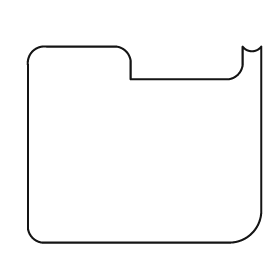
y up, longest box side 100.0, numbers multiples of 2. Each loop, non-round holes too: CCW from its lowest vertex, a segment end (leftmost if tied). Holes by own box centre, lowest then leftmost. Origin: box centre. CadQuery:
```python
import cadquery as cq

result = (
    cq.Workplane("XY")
    .moveTo(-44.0, -42.0)
    .lineTo(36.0, -42.0)
    .threePointArc((46.0, -38.0), (50.0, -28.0))
    .lineTo(50.0, 42.0)
    .threePointArc((46.0, 40.0), (42.0, 42.0))
    .lineTo(42.0, 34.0)
    .threePointArc((40.0, 30.0), (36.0, 28.0))
    .lineTo(-6.0, 28.0)
    .lineTo(-6.0, 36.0)
    .threePointArc((-8.0, 40.0), (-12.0, 42.0))
    .lineTo(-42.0, 42.0)
    .threePointArc((-48.0, 40.0), (-50.0, 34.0))
    .lineTo(-50.0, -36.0)
    .threePointArc((-48.0, -40.0), (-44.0, -42.0))
    .close()
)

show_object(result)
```